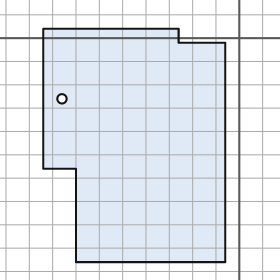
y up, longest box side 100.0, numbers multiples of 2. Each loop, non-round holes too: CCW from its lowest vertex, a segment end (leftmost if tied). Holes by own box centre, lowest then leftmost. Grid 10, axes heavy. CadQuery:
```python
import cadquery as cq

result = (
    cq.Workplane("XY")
    .moveTo(-70.0, -96.0)
    .lineTo(-6.0, -96.0)
    .lineTo(-6.0, -2.0)
    .lineTo(-26.0, -2.0)
    .lineTo(-26.0, 4.0)
    .lineTo(-84.0, 4.0)
    .lineTo(-84.0, -56.0)
    .lineTo(-70.0, -56.0)
    .close()
    .moveTo(-76.0, -26.0)
    .circle(2.0)
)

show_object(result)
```